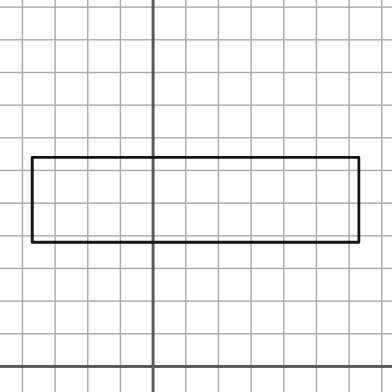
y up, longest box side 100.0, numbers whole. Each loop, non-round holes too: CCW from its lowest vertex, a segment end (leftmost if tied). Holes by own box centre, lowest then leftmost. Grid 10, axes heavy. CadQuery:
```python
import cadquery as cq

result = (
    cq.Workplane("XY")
    .moveTo(-37.0, 38.0)
    .lineTo(63.0, 38.0)
    .lineTo(63.0, 64.0)
    .lineTo(-37.0, 64.0)
    .close()
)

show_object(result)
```